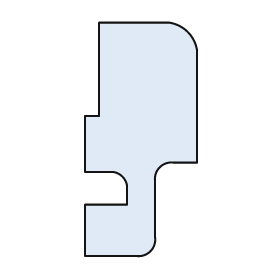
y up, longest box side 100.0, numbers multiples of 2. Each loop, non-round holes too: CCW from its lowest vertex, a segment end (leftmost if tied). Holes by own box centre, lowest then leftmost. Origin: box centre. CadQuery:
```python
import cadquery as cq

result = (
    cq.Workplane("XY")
    .moveTo(-24.0, -50.0)
    .lineTo(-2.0, -50.0)
    .threePointArc((4.0, -48.0), (6.0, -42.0))
    .lineTo(6.0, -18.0)
    .threePointArc((8.0, -12.0), (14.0, -10.0))
    .lineTo(24.0, -10.0)
    .lineTo(24.0, 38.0)
    .threePointArc((20.0, 46.0), (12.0, 50.0))
    .lineTo(-18.0, 50.0)
    .lineTo(-18.0, 10.0)
    .lineTo(-24.0, 10.0)
    .lineTo(-24.0, -14.0)
    .lineTo(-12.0, -14.0)
    .threePointArc((-8.0, -16.0), (-6.0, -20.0))
    .lineTo(-6.0, -28.0)
    .lineTo(-24.0, -28.0)
    .close()
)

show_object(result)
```